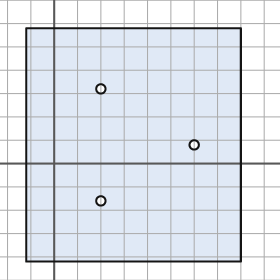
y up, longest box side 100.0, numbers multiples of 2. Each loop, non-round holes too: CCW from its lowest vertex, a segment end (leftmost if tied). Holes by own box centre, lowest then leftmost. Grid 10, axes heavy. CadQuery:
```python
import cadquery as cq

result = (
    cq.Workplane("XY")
    .moveTo(-12.0, -42.0)
    .lineTo(80.0, -42.0)
    .lineTo(80.0, 58.0)
    .lineTo(-12.0, 58.0)
    .close()
    .moveTo(20.0, -16.0)
    .circle(2.0)
    .moveTo(60.0, 8.0)
    .circle(2.0)
    .moveTo(20.0, 32.0)
    .circle(2.0)
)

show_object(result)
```